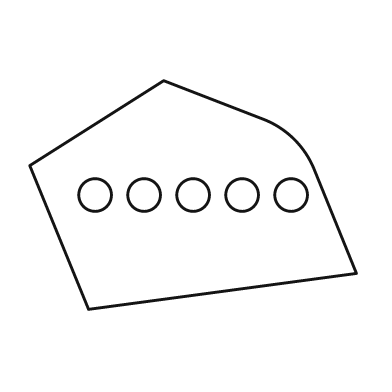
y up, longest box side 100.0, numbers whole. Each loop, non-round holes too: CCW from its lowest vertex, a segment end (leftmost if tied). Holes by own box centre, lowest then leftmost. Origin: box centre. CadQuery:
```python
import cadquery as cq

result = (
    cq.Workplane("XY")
    .moveTo(-32.0, -35.0)
    .lineTo(50.0, -24.0)
    .lineTo(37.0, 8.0)
    .threePointArc((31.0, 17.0), (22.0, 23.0))
    .lineTo(-9.0, 35.0)
    .lineTo(-50.0, 9.0)
    .close()
    .moveTo(-30.0, 0.0)
    .circle(5.0)
    .moveTo(-15.0, 0.0)
    .circle(5.0)
    .moveTo(0.0, 0.0)
    .circle(5.0)
    .moveTo(15.0, 0.0)
    .circle(5.0)
    .moveTo(30.0, 0.0)
    .circle(5.0)
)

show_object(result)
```